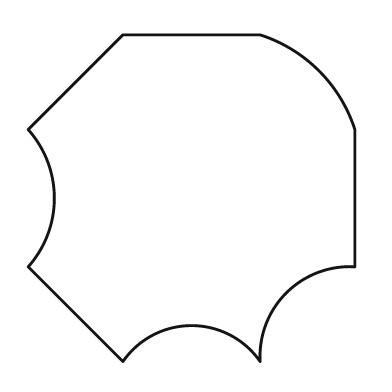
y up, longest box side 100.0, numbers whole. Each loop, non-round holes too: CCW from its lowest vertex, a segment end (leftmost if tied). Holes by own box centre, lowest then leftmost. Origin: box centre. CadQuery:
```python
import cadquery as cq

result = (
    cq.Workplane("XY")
    .moveTo(-21.0, -50.0)
    .threePointArc((0.0, -39.0), (21.0, -50.0))
    .threePointArc((29.0, -29.0), (50.0, -21.0))
    .lineTo(50.0, 21.0)
    .threePointArc((39.0, 39.0), (21.0, 50.0))
    .lineTo(-21.0, 50.0)
    .lineTo(-50.0, 21.0)
    .threePointArc((-42.0, 0.0), (-50.0, -21.0))
    .close()
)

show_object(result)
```